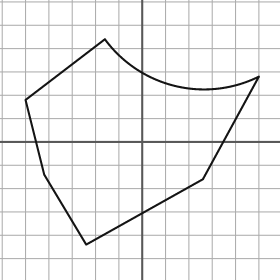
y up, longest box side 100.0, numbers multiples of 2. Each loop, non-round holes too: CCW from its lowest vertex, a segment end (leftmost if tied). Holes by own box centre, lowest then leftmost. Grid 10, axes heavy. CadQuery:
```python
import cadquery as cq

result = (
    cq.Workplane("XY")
    .moveTo(-24.0, -44.0)
    .lineTo(26.0, -16.0)
    .lineTo(50.0, 28.0)
    .threePointArc((14.0, 24.0), (-16.0, 44.0))
    .lineTo(-50.0, 18.0)
    .lineTo(-42.0, -14.0)
    .close()
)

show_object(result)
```